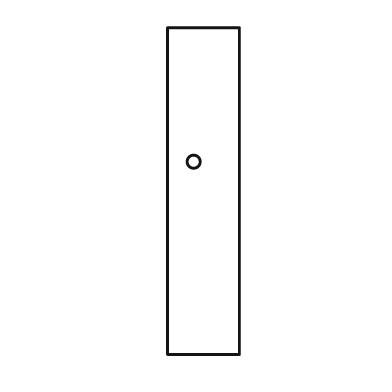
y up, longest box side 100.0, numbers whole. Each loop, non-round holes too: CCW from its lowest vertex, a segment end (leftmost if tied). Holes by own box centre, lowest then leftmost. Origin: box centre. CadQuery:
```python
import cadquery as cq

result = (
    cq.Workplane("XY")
    .moveTo(-11.0, -50.0)
    .lineTo(11.0, -50.0)
    .lineTo(11.0, 50.0)
    .lineTo(-11.0, 50.0)
    .close()
    .moveTo(-3.0, 9.0)
    .circle(2.0)
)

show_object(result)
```